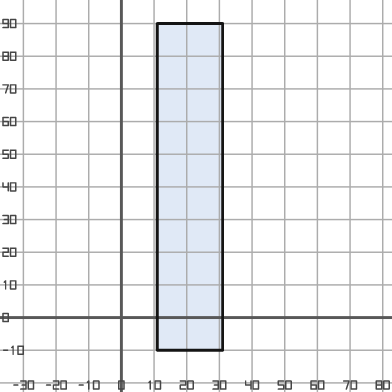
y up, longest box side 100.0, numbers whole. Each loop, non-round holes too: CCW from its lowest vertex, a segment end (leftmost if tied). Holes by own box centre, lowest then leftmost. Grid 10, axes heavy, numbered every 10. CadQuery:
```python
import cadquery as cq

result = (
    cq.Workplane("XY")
    .moveTo(11.0, -10.0)
    .lineTo(31.0, -10.0)
    .lineTo(31.0, 90.0)
    .lineTo(11.0, 90.0)
    .close()
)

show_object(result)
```